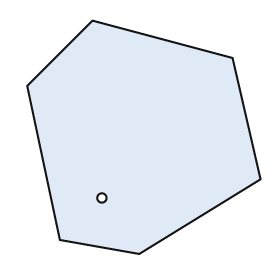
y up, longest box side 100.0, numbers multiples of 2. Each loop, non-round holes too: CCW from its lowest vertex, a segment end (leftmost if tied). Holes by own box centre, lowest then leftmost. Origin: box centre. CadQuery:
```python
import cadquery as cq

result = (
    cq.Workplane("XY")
    .moveTo(-2.0, -50.0)
    .lineTo(50.0, -18.0)
    .lineTo(38.0, 34.0)
    .lineTo(-22.0, 50.0)
    .lineTo(-50.0, 22.0)
    .lineTo(-36.0, -44.0)
    .close()
    .moveTo(-18.0, -26.0)
    .circle(2.0)
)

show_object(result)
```